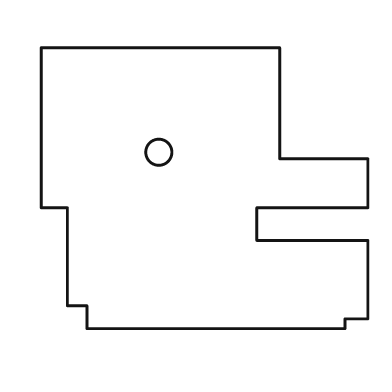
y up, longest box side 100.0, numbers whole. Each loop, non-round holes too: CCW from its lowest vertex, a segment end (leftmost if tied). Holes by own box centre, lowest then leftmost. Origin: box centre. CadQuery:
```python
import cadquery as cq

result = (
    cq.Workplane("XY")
    .moveTo(-36.0, -43.0)
    .lineTo(43.0, -43.0)
    .lineTo(43.0, -40.0)
    .lineTo(50.0, -40.0)
    .lineTo(50.0, -16.0)
    .lineTo(16.0, -16.0)
    .lineTo(16.0, -6.0)
    .lineTo(50.0, -6.0)
    .lineTo(50.0, 9.0)
    .lineTo(23.0, 9.0)
    .lineTo(23.0, 43.0)
    .lineTo(-50.0, 43.0)
    .lineTo(-50.0, -6.0)
    .lineTo(-42.0, -6.0)
    .lineTo(-42.0, -36.0)
    .lineTo(-36.0, -36.0)
    .close()
    .moveTo(-14.0, 11.0)
    .circle(4.0)
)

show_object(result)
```